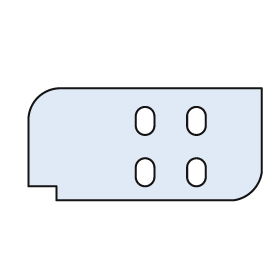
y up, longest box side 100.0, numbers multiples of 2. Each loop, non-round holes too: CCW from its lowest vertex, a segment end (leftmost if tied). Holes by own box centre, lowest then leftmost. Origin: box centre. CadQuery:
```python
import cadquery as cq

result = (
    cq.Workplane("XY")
    .moveTo(-38.0, -24.0)
    .lineTo(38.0, -24.0)
    .threePointArc((46.0, -20.0), (50.0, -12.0))
    .lineTo(50.0, 24.0)
    .lineTo(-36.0, 24.0)
    .threePointArc((-46.0, 20.0), (-50.0, 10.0))
    .lineTo(-50.0, -18.0)
    .lineTo(-38.0, -18.0)
    .close()
    .moveTo(-4.0, -14.0)
    .threePointArc((0.0, -18.0), (4.0, -14.0))
    .lineTo(4.0, -10.0)
    .threePointArc((0.0, -6.0), (-4.0, -10.0))
    .close()
    .moveTo(18.0, -14.0)
    .threePointArc((22.0, -18.0), (26.0, -14.0))
    .lineTo(26.0, -10.0)
    .threePointArc((22.0, -6.0), (18.0, -10.0))
    .close()
    .moveTo(-4.0, 8.0)
    .threePointArc((0.0, 4.0), (4.0, 8.0))
    .lineTo(4.0, 12.0)
    .threePointArc((0.0, 16.0), (-4.0, 12.0))
    .close()
    .moveTo(18.0, 8.0)
    .threePointArc((22.0, 4.0), (26.0, 8.0))
    .lineTo(26.0, 12.0)
    .threePointArc((22.0, 16.0), (18.0, 12.0))
    .close()
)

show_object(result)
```